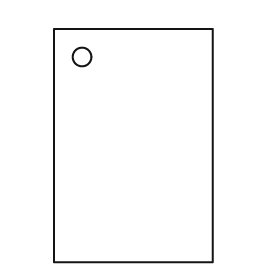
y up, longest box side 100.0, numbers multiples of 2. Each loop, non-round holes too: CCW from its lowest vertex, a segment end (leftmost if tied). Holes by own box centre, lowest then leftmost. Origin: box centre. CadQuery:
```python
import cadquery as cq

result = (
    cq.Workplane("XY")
    .moveTo(-34.0, -50.0)
    .lineTo(34.0, -50.0)
    .lineTo(34.0, 50.0)
    .lineTo(-34.0, 50.0)
    .close()
    .moveTo(-22.0, 38.0)
    .circle(4.0)
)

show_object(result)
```